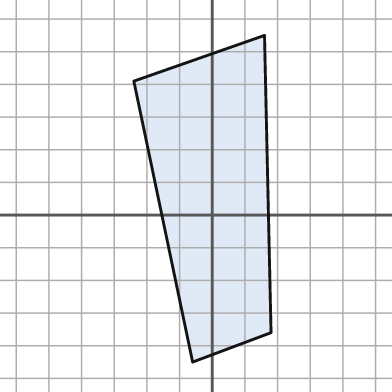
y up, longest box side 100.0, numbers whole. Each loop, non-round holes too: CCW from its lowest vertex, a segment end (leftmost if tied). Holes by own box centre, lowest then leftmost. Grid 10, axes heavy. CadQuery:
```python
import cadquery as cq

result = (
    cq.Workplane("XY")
    .moveTo(-6.0, -45.0)
    .lineTo(18.0, -36.0)
    .lineTo(16.0, 55.0)
    .lineTo(-24.0, 41.0)
    .close()
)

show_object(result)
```